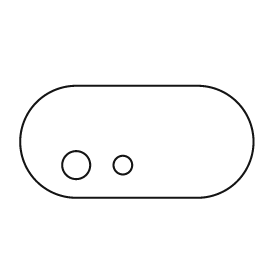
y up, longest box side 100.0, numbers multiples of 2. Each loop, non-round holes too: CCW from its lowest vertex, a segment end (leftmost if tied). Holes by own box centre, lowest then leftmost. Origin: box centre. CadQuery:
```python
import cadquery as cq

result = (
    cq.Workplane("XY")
    .moveTo(-26.0, -24.0)
    .lineTo(26.0, -24.0)
    .threePointArc((50.0, 0.0), (26.0, 24.0))
    .lineTo(-26.0, 24.0)
    .threePointArc((-50.0, 0.0), (-26.0, -24.0))
    .close()
    .moveTo(-26.0, -10.0)
    .circle(6.0)
    .moveTo(-6.0, -10.0)
    .circle(4.0)
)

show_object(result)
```